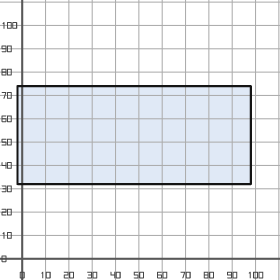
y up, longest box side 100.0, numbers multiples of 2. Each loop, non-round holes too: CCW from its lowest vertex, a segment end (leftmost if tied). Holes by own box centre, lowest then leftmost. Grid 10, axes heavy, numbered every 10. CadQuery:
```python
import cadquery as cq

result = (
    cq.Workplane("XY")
    .moveTo(-2.0, 32.0)
    .lineTo(98.0, 32.0)
    .lineTo(98.0, 74.0)
    .lineTo(-2.0, 74.0)
    .close()
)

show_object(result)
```